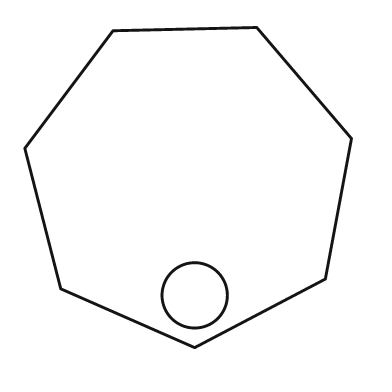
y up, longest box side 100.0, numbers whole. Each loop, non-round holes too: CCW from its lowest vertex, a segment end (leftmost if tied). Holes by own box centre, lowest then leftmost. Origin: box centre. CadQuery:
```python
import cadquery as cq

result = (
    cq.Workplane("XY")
    .moveTo(2.0, -49.0)
    .lineTo(42.0, -28.0)
    .lineTo(50.0, 15.0)
    .lineTo(21.0, 49.0)
    .lineTo(-23.0, 48.0)
    .lineTo(-50.0, 12.0)
    .lineTo(-39.0, -31.0)
    .close()
    .moveTo(2.0, -33.0)
    .circle(10.0)
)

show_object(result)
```